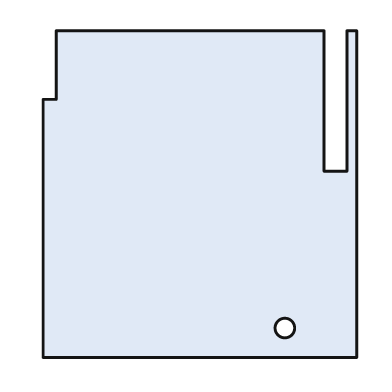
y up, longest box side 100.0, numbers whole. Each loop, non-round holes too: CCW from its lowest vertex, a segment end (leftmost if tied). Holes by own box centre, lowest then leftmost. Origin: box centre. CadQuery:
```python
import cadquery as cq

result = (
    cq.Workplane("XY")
    .moveTo(-48.0, -50.0)
    .lineTo(48.0, -50.0)
    .lineTo(48.0, 50.0)
    .lineTo(45.0, 50.0)
    .lineTo(45.0, 7.0)
    .lineTo(38.0, 7.0)
    .lineTo(38.0, 50.0)
    .lineTo(-44.0, 50.0)
    .lineTo(-44.0, 29.0)
    .lineTo(-48.0, 29.0)
    .close()
    .moveTo(26.0, -41.0)
    .circle(3.0)
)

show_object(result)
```